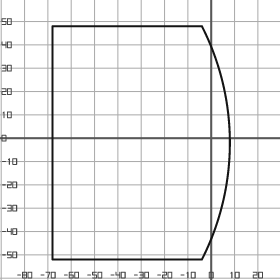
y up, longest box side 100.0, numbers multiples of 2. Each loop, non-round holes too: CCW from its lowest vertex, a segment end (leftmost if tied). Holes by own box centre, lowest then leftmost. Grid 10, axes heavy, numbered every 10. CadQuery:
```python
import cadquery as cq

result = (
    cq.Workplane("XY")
    .moveTo(-68.0, -52.0)
    .lineTo(-4.0, -52.0)
    .threePointArc((8.0, -2.0), (-4.0, 48.0))
    .lineTo(-68.0, 48.0)
    .close()
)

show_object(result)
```